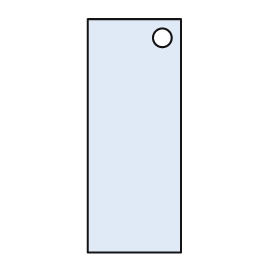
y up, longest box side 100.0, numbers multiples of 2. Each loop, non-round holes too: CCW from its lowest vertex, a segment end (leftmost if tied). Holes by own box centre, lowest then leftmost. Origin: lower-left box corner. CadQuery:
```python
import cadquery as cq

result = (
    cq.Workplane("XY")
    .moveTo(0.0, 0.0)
    .lineTo(40.0, 0.0)
    .lineTo(40.0, 100.0)
    .lineTo(0.0, 100.0)
    .close()
    .moveTo(32.0, 92.0)
    .circle(4.0)
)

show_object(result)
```